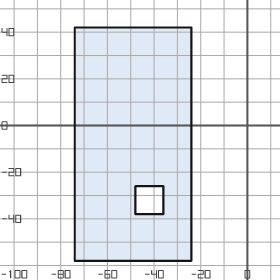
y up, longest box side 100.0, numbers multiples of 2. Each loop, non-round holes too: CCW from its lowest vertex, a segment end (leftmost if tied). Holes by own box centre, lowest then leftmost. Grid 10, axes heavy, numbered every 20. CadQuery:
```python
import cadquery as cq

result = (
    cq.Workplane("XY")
    .moveTo(-74.0, -58.0)
    .lineTo(-24.0, -58.0)
    .lineTo(-24.0, 42.0)
    .lineTo(-74.0, 42.0)
    .close()
    .moveTo(-48.0, -38.0)
    .lineTo(-36.0, -38.0)
    .lineTo(-36.0, -26.0)
    .lineTo(-48.0, -26.0)
    .close()
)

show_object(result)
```